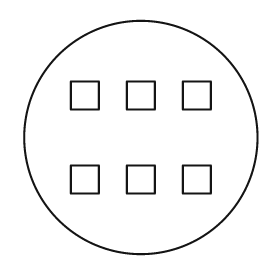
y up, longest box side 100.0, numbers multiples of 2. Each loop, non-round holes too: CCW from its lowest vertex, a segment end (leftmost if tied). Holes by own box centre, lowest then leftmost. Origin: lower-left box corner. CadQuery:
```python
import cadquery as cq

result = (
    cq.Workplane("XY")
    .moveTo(50.0, 50.0)
    .circle(50.0)
    .moveTo(20.0, 26.0)
    .lineTo(32.0, 26.0)
    .lineTo(32.0, 38.0)
    .lineTo(20.0, 38.0)
    .close()
    .moveTo(44.0, 26.0)
    .lineTo(56.0, 26.0)
    .lineTo(56.0, 38.0)
    .lineTo(44.0, 38.0)
    .close()
    .moveTo(68.0, 26.0)
    .lineTo(80.0, 26.0)
    .lineTo(80.0, 38.0)
    .lineTo(68.0, 38.0)
    .close()
    .moveTo(20.0, 62.0)
    .lineTo(32.0, 62.0)
    .lineTo(32.0, 74.0)
    .lineTo(20.0, 74.0)
    .close()
    .moveTo(44.0, 62.0)
    .lineTo(56.0, 62.0)
    .lineTo(56.0, 74.0)
    .lineTo(44.0, 74.0)
    .close()
    .moveTo(68.0, 62.0)
    .lineTo(80.0, 62.0)
    .lineTo(80.0, 74.0)
    .lineTo(68.0, 74.0)
    .close()
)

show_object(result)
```